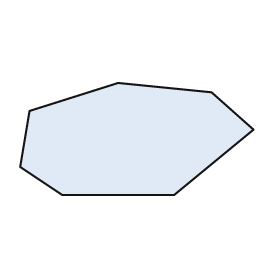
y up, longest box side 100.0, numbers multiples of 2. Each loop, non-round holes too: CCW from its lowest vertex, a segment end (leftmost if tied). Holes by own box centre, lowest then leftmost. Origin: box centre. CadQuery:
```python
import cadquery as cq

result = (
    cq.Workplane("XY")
    .moveTo(-32.0, -24.0)
    .lineTo(16.0, -24.0)
    .lineTo(50.0, 4.0)
    .lineTo(32.0, 20.0)
    .lineTo(-8.0, 24.0)
    .lineTo(-46.0, 12.0)
    .lineTo(-50.0, -12.0)
    .close()
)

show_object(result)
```